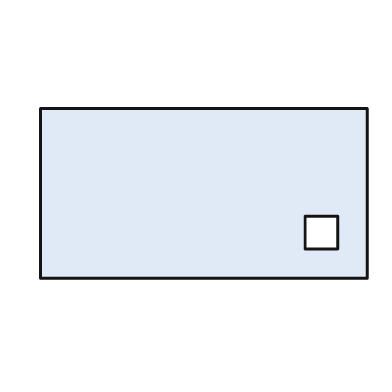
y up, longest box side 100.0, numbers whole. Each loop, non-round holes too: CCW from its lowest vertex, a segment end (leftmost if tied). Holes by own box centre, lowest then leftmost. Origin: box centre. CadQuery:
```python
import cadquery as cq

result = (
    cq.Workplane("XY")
    .moveTo(-50.0, -26.0)
    .lineTo(50.0, -26.0)
    .lineTo(50.0, 26.0)
    .lineTo(-50.0, 26.0)
    .close()
    .moveTo(31.0, -17.0)
    .lineTo(41.0, -17.0)
    .lineTo(41.0, -7.0)
    .lineTo(31.0, -7.0)
    .close()
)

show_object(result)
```